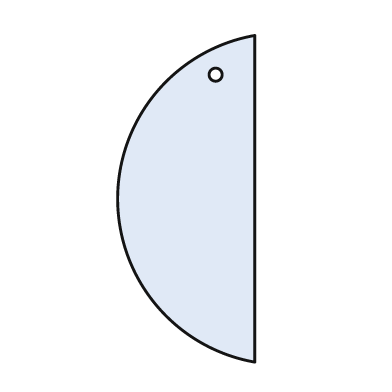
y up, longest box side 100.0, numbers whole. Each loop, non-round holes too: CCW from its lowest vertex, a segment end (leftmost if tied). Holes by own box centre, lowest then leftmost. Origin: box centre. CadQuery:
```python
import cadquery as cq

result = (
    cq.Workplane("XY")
    .moveTo(21.0, -50.0)
    .lineTo(21.0, 50.0)
    .threePointArc((-21.0, 0.0), (21.0, -50.0))
    .close()
    .moveTo(9.0, 38.0)
    .circle(2.0)
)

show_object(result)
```